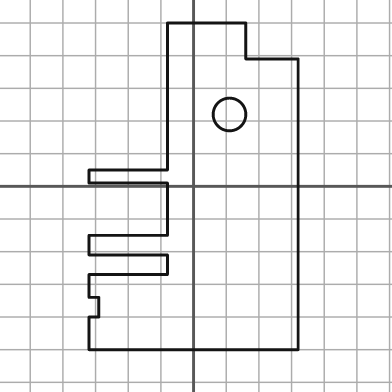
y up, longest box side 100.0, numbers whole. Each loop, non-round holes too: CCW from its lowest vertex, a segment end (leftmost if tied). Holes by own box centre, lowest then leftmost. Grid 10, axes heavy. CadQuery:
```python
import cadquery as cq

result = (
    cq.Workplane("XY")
    .moveTo(-32.0, -50.0)
    .lineTo(32.0, -50.0)
    .lineTo(32.0, 39.0)
    .lineTo(16.0, 39.0)
    .lineTo(16.0, 50.0)
    .lineTo(-8.0, 50.0)
    .lineTo(-8.0, 5.0)
    .lineTo(-32.0, 5.0)
    .lineTo(-32.0, 1.0)
    .lineTo(-8.0, 1.0)
    .lineTo(-8.0, -15.0)
    .lineTo(-32.0, -15.0)
    .lineTo(-32.0, -21.0)
    .lineTo(-8.0, -21.0)
    .lineTo(-8.0, -27.0)
    .lineTo(-32.0, -27.0)
    .lineTo(-32.0, -34.0)
    .lineTo(-29.0, -34.0)
    .lineTo(-29.0, -40.0)
    .lineTo(-32.0, -40.0)
    .close()
    .moveTo(11.0, 22.0)
    .circle(5.0)
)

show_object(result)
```